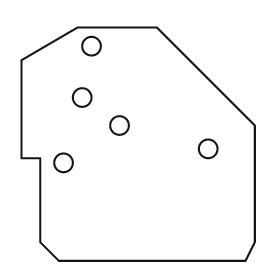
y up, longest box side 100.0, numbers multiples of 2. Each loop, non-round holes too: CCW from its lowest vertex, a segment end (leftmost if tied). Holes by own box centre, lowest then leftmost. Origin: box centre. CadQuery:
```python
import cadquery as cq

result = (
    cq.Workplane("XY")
    .moveTo(-34.0, -50.0)
    .lineTo(46.0, -50.0)
    .lineTo(50.0, -42.0)
    .lineTo(50.0, 8.0)
    .lineTo(8.0, 50.0)
    .lineTo(-26.0, 50.0)
    .lineTo(-50.0, 36.0)
    .lineTo(-50.0, -6.0)
    .lineTo(-42.0, -6.0)
    .lineTo(-42.0, -42.0)
    .close()
    .moveTo(-32.0, -8.0)
    .circle(4.0)
    .moveTo(30.0, -2.0)
    .circle(4.0)
    .moveTo(-8.0, 8.0)
    .circle(4.0)
    .moveTo(-24.0, 20.0)
    .circle(4.0)
    .moveTo(-20.0, 42.0)
    .circle(4.0)
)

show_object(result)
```